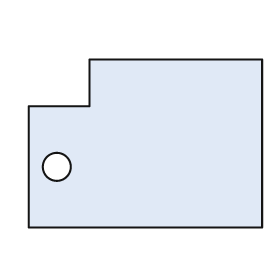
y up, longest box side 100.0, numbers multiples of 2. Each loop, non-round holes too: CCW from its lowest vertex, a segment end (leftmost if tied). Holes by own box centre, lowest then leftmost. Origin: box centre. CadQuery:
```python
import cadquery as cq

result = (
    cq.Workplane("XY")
    .moveTo(-50.0, -36.0)
    .lineTo(50.0, -36.0)
    .lineTo(50.0, 36.0)
    .lineTo(-24.0, 36.0)
    .lineTo(-24.0, 16.0)
    .lineTo(-50.0, 16.0)
    .close()
    .moveTo(-38.0, -10.0)
    .circle(6.0)
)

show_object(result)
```